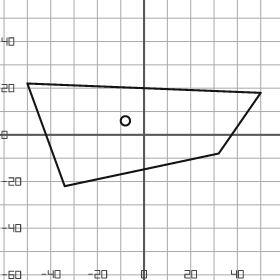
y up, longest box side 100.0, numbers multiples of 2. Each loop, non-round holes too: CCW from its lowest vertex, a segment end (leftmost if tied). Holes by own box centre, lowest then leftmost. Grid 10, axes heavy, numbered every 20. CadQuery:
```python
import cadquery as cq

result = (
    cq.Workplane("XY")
    .moveTo(-34.0, -22.0)
    .lineTo(32.0, -8.0)
    .lineTo(50.0, 18.0)
    .lineTo(-50.0, 22.0)
    .close()
    .moveTo(-8.0, 6.0)
    .circle(2.0)
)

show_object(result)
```